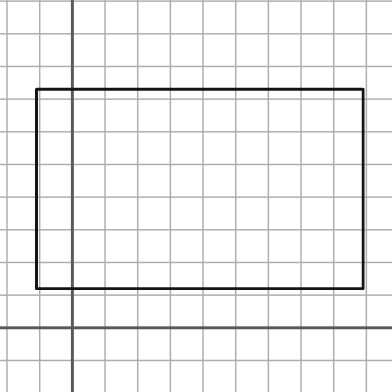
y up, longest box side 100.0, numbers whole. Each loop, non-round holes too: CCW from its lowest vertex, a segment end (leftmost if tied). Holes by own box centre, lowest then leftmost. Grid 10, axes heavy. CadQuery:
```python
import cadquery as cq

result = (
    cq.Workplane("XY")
    .moveTo(-11.0, 12.0)
    .lineTo(89.0, 12.0)
    .lineTo(89.0, 73.0)
    .lineTo(-11.0, 73.0)
    .close()
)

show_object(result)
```